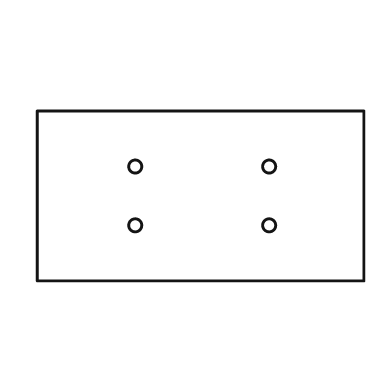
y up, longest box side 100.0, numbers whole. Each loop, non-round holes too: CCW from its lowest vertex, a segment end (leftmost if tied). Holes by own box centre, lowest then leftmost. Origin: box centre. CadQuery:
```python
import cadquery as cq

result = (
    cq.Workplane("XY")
    .moveTo(-50.0, -26.0)
    .lineTo(50.0, -26.0)
    .lineTo(50.0, 26.0)
    .lineTo(-50.0, 26.0)
    .close()
    .moveTo(-20.0, -9.0)
    .circle(2.0)
    .moveTo(21.0, -9.0)
    .circle(2.0)
    .moveTo(-20.0, 9.0)
    .circle(2.0)
    .moveTo(21.0, 9.0)
    .circle(2.0)
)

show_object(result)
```